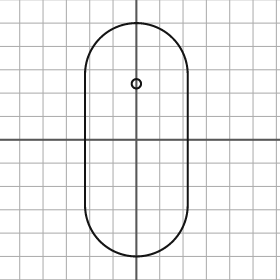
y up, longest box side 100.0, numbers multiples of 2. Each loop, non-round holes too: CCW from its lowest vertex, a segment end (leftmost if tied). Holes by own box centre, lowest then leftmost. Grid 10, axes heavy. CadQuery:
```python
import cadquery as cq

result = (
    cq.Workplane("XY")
    .moveTo(-22.0, -28.0)
    .threePointArc((0.0, -50.0), (22.0, -28.0))
    .lineTo(22.0, 28.0)
    .threePointArc((0.0, 50.0), (-22.0, 28.0))
    .close()
    .moveTo(0.0, 24.0)
    .circle(2.0)
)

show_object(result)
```